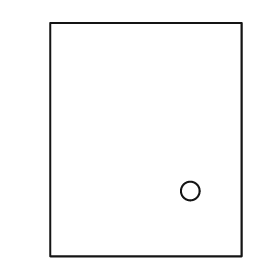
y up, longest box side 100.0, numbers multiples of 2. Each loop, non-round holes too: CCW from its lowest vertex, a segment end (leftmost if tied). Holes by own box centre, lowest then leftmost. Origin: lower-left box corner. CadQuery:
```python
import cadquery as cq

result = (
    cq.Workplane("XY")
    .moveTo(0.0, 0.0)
    .lineTo(82.0, 0.0)
    .lineTo(82.0, 100.0)
    .lineTo(0.0, 100.0)
    .close()
    .moveTo(60.0, 28.0)
    .circle(4.0)
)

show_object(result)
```